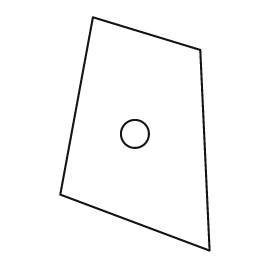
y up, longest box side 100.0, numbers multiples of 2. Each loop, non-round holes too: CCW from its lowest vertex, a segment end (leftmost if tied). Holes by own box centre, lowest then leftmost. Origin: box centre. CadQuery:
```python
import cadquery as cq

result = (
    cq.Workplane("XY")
    .moveTo(32.0, -50.0)
    .lineTo(28.0, 36.0)
    .lineTo(-18.0, 50.0)
    .lineTo(-32.0, -26.0)
    .close()
    .moveTo(0.0, 0.0)
    .circle(6.0)
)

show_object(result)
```